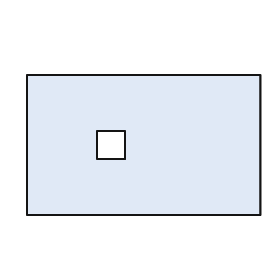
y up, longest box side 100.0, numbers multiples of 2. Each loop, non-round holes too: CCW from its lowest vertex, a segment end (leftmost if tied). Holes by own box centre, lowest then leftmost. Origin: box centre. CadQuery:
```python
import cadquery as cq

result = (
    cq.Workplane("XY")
    .moveTo(-50.0, -30.0)
    .lineTo(50.0, -30.0)
    .lineTo(50.0, 30.0)
    .lineTo(-50.0, 30.0)
    .close()
    .moveTo(-20.0, -6.0)
    .lineTo(-8.0, -6.0)
    .lineTo(-8.0, 6.0)
    .lineTo(-20.0, 6.0)
    .close()
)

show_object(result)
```